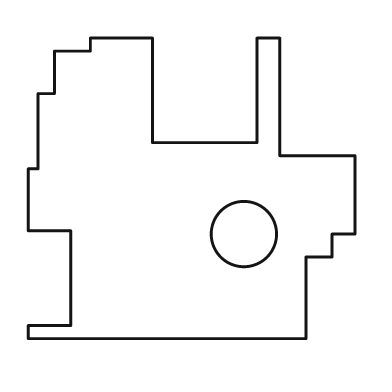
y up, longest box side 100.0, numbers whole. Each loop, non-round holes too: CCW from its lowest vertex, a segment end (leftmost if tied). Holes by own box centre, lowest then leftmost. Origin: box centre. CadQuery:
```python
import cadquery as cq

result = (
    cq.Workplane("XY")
    .moveTo(-50.0, -46.0)
    .lineTo(35.0, -46.0)
    .lineTo(35.0, -21.0)
    .lineTo(43.0, -21.0)
    .lineTo(43.0, -14.0)
    .lineTo(50.0, -14.0)
    .lineTo(50.0, 10.0)
    .lineTo(27.0, 10.0)
    .lineTo(27.0, 46.0)
    .lineTo(20.0, 46.0)
    .lineTo(20.0, 14.0)
    .lineTo(-12.0, 14.0)
    .lineTo(-12.0, 46.0)
    .lineTo(-31.0, 46.0)
    .lineTo(-31.0, 42.0)
    .lineTo(-42.0, 42.0)
    .lineTo(-42.0, 29.0)
    .lineTo(-47.0, 29.0)
    .lineTo(-47.0, 6.0)
    .lineTo(-50.0, 6.0)
    .lineTo(-50.0, -13.0)
    .lineTo(-37.0, -13.0)
    .lineTo(-37.0, -42.0)
    .lineTo(-50.0, -42.0)
    .close()
    .moveTo(16.0, -14.0)
    .circle(10.0)
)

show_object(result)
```